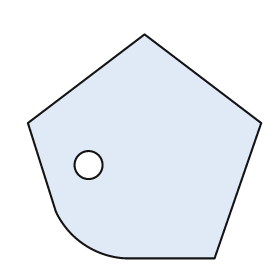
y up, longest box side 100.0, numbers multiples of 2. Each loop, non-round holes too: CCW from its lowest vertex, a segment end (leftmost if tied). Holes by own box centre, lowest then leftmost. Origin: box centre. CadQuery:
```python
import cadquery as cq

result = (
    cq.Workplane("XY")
    .moveTo(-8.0, -48.0)
    .lineTo(30.0, -48.0)
    .lineTo(50.0, 10.0)
    .lineTo(0.0, 48.0)
    .lineTo(-50.0, 10.0)
    .lineTo(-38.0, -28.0)
    .threePointArc((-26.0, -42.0), (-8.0, -48.0))
    .close()
    .moveTo(-24.0, -8.0)
    .circle(6.0)
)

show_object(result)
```